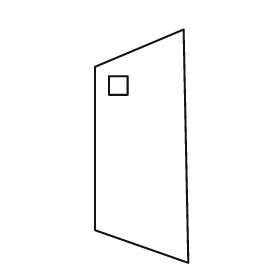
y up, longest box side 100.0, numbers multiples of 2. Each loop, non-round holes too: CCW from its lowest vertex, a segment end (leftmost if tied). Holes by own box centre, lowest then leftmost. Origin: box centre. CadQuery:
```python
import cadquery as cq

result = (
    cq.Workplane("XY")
    .moveTo(20.0, -50.0)
    .lineTo(18.0, 50.0)
    .lineTo(-20.0, 34.0)
    .lineTo(-20.0, -36.0)
    .close()
    .moveTo(-14.0, 22.0)
    .lineTo(-6.0, 22.0)
    .lineTo(-6.0, 30.0)
    .lineTo(-14.0, 30.0)
    .close()
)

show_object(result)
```